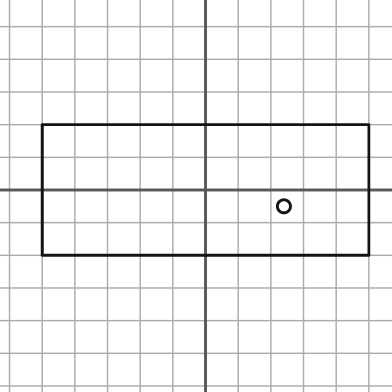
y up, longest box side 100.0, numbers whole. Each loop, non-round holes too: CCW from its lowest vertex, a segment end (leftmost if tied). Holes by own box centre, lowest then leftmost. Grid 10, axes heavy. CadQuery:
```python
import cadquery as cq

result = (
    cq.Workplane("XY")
    .moveTo(-50.0, -20.0)
    .lineTo(50.0, -20.0)
    .lineTo(50.0, 20.0)
    .lineTo(-50.0, 20.0)
    .close()
    .moveTo(24.0, -5.0)
    .circle(2.0)
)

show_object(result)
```